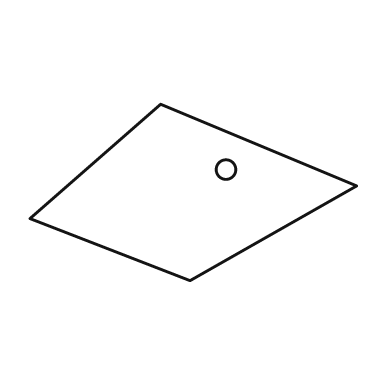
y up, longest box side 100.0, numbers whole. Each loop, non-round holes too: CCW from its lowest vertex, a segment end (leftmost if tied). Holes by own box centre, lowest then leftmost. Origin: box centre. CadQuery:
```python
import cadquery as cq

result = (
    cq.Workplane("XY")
    .moveTo(-1.0, -27.0)
    .lineTo(50.0, 2.0)
    .lineTo(-10.0, 27.0)
    .lineTo(-50.0, -8.0)
    .close()
    .moveTo(10.0, 7.0)
    .circle(3.0)
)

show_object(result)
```